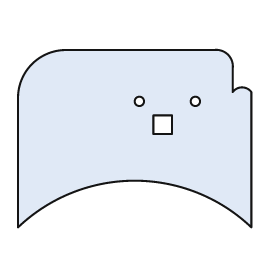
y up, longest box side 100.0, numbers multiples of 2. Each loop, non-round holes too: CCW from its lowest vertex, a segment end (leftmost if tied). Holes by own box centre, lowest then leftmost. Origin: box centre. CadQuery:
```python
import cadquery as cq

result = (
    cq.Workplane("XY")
    .moveTo(-50.0, -38.0)
    .threePointArc((0.0, -18.0), (50.0, -38.0))
    .lineTo(50.0, 20.0)
    .threePointArc((46.0, 22.0), (42.0, 20.0))
    .lineTo(42.0, 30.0)
    .threePointArc((40.0, 36.0), (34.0, 38.0))
    .lineTo(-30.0, 38.0)
    .threePointArc((-44.0, 32.0), (-50.0, 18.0))
    .close()
    .moveTo(8.0, 2.0)
    .lineTo(16.0, 2.0)
    .lineTo(16.0, 10.0)
    .lineTo(8.0, 10.0)
    .close()
    .moveTo(2.0, 16.0)
    .circle(2.0)
    .moveTo(26.0, 16.0)
    .circle(2.0)
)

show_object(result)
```